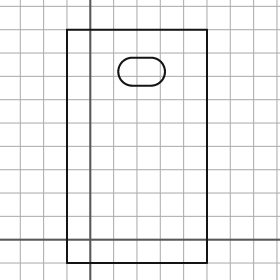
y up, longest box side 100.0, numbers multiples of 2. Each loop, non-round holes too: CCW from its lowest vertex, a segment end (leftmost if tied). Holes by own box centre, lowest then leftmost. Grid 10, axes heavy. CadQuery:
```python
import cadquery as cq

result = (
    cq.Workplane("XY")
    .moveTo(-10.0, -10.0)
    .lineTo(50.0, -10.0)
    .lineTo(50.0, 90.0)
    .lineTo(-10.0, 90.0)
    .close()
    .moveTo(18.0, 66.0)
    .lineTo(26.0, 66.0)
    .threePointArc((32.0, 72.0), (26.0, 78.0))
    .lineTo(18.0, 78.0)
    .threePointArc((12.0, 72.0), (18.0, 66.0))
    .close()
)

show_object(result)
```